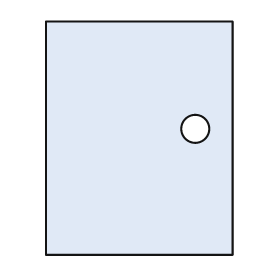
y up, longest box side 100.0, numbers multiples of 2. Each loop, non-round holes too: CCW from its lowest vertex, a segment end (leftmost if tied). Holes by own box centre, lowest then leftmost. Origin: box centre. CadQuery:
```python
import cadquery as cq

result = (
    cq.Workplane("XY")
    .moveTo(-40.0, -50.0)
    .lineTo(40.0, -50.0)
    .lineTo(40.0, 50.0)
    .lineTo(-40.0, 50.0)
    .close()
    .moveTo(24.0, 4.0)
    .circle(6.0)
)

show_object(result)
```